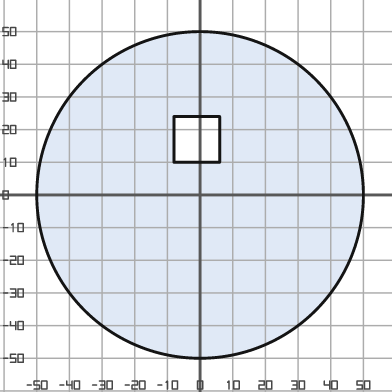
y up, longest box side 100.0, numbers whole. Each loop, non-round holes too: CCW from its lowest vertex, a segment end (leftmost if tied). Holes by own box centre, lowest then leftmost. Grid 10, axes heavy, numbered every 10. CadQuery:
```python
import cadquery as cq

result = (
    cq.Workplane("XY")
    .moveTo(0.0, 0.0)
    .circle(50.0)
    .moveTo(-8.0, 10.0)
    .lineTo(6.0, 10.0)
    .lineTo(6.0, 24.0)
    .lineTo(-8.0, 24.0)
    .close()
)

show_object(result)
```